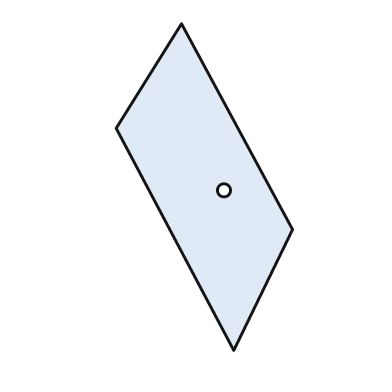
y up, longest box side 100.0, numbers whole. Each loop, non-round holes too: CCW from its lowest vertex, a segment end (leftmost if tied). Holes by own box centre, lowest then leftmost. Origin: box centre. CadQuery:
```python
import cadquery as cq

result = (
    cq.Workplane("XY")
    .moveTo(9.0, -50.0)
    .lineTo(27.0, -13.0)
    .lineTo(-7.0, 50.0)
    .lineTo(-27.0, 18.0)
    .close()
    .moveTo(6.0, -1.0)
    .circle(2.0)
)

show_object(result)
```